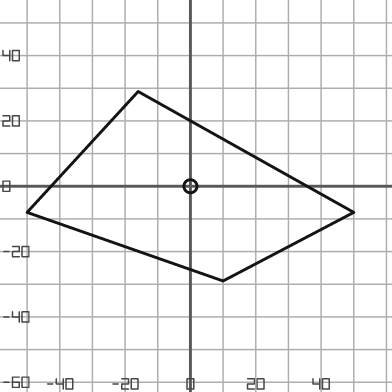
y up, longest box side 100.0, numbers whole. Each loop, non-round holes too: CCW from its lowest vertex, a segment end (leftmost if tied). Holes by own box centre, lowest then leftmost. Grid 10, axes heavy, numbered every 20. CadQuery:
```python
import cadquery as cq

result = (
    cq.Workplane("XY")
    .moveTo(10.0, -29.0)
    .lineTo(50.0, -8.0)
    .lineTo(-16.0, 29.0)
    .lineTo(-50.0, -8.0)
    .close()
    .moveTo(0.0, 0.0)
    .circle(2.0)
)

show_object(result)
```